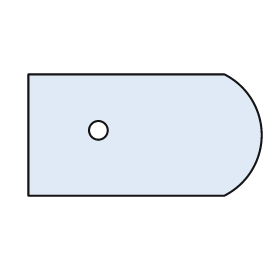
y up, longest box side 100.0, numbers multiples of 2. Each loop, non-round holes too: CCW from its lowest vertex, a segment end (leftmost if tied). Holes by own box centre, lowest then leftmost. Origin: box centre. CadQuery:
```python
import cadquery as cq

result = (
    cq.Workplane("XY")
    .moveTo(-50.0, -26.0)
    .lineTo(34.0, -26.0)
    .threePointArc((50.0, 0.0), (34.0, 26.0))
    .lineTo(-50.0, 26.0)
    .close()
    .moveTo(-20.0, 2.0)
    .circle(4.0)
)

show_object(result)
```